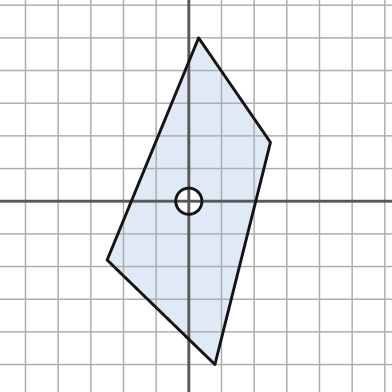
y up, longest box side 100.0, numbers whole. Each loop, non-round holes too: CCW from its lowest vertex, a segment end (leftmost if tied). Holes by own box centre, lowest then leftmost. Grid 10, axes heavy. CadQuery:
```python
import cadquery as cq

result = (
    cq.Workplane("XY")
    .moveTo(8.0, -50.0)
    .lineTo(25.0, 18.0)
    .lineTo(3.0, 50.0)
    .lineTo(-25.0, -18.0)
    .close()
    .moveTo(0.0, 0.0)
    .circle(4.0)
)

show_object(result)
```